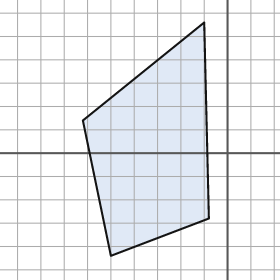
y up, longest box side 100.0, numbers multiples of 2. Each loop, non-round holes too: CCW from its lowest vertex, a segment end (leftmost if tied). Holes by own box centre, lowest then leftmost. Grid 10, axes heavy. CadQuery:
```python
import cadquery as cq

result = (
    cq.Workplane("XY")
    .moveTo(-50.0, -44.0)
    .lineTo(-8.0, -28.0)
    .lineTo(-10.0, 56.0)
    .lineTo(-62.0, 14.0)
    .close()
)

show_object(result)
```